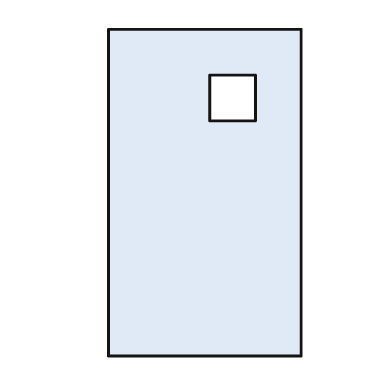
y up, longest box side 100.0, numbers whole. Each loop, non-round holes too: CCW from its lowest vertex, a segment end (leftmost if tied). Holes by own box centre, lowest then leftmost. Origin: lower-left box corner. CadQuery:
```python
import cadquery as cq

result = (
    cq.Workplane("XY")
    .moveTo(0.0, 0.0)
    .lineTo(59.0, 0.0)
    .lineTo(59.0, 100.0)
    .lineTo(0.0, 100.0)
    .close()
    .moveTo(31.0, 72.0)
    .lineTo(45.0, 72.0)
    .lineTo(45.0, 86.0)
    .lineTo(31.0, 86.0)
    .close()
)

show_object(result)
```